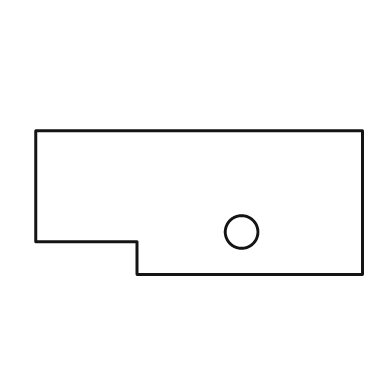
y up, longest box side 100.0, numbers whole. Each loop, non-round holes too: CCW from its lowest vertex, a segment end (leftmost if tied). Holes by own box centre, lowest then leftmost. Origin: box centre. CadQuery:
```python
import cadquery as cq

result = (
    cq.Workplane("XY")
    .moveTo(-19.0, -22.0)
    .lineTo(50.0, -22.0)
    .lineTo(50.0, 22.0)
    .lineTo(-50.0, 22.0)
    .lineTo(-50.0, -12.0)
    .lineTo(-19.0, -12.0)
    .close()
    .moveTo(13.0, -9.0)
    .circle(5.0)
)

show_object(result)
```